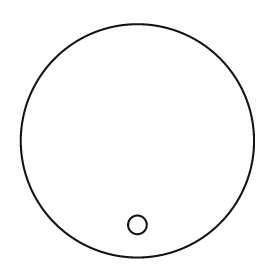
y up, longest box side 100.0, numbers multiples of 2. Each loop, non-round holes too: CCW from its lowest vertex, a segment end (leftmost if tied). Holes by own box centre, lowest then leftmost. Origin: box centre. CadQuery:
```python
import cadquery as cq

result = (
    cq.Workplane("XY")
    .moveTo(0.0, 0.0)
    .circle(50.0)
    .moveTo(0.0, -36.0)
    .circle(4.0)
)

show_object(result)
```